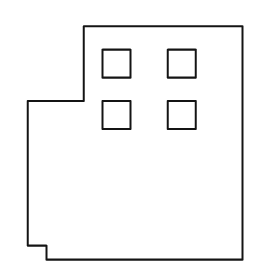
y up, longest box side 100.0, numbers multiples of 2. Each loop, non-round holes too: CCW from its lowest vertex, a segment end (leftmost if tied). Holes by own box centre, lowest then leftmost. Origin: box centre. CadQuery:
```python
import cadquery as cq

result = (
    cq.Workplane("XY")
    .moveTo(-38.0, -50.0)
    .lineTo(46.0, -50.0)
    .lineTo(46.0, 50.0)
    .lineTo(-22.0, 50.0)
    .lineTo(-22.0, 18.0)
    .lineTo(-46.0, 18.0)
    .lineTo(-46.0, -44.0)
    .lineTo(-38.0, -44.0)
    .close()
    .moveTo(-14.0, 6.0)
    .lineTo(-2.0, 6.0)
    .lineTo(-2.0, 18.0)
    .lineTo(-14.0, 18.0)
    .close()
    .moveTo(14.0, 6.0)
    .lineTo(26.0, 6.0)
    .lineTo(26.0, 18.0)
    .lineTo(14.0, 18.0)
    .close()
    .moveTo(-14.0, 28.0)
    .lineTo(-2.0, 28.0)
    .lineTo(-2.0, 40.0)
    .lineTo(-14.0, 40.0)
    .close()
    .moveTo(14.0, 28.0)
    .lineTo(26.0, 28.0)
    .lineTo(26.0, 40.0)
    .lineTo(14.0, 40.0)
    .close()
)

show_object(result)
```